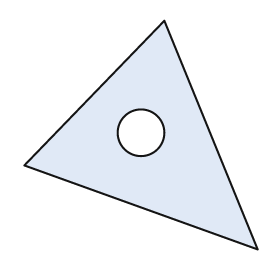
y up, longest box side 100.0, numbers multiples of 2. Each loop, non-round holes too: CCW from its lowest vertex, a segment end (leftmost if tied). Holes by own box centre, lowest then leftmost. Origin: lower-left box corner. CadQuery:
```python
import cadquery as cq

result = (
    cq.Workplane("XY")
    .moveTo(100.0, 0.0)
    .lineTo(60.0, 98.0)
    .lineTo(0.0, 36.0)
    .close()
    .moveTo(50.0, 50.0)
    .circle(10.0)
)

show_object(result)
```